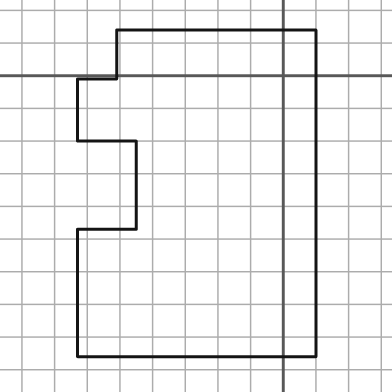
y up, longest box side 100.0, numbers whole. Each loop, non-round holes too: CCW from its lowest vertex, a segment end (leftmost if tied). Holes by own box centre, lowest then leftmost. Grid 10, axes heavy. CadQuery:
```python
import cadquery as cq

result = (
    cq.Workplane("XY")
    .moveTo(-63.0, -86.0)
    .lineTo(10.0, -86.0)
    .lineTo(10.0, 14.0)
    .lineTo(-51.0, 14.0)
    .lineTo(-51.0, -1.0)
    .lineTo(-63.0, -1.0)
    .lineTo(-63.0, -20.0)
    .lineTo(-45.0, -20.0)
    .lineTo(-45.0, -47.0)
    .lineTo(-63.0, -47.0)
    .close()
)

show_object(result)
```